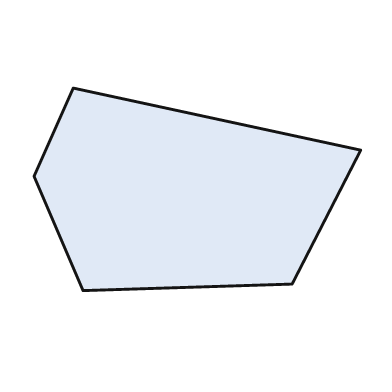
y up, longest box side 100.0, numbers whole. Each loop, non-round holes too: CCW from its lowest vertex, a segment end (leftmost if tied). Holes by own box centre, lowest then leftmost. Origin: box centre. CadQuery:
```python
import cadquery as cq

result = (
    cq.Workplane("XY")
    .moveTo(-35.0, -31.0)
    .lineTo(29.0, -29.0)
    .lineTo(50.0, 12.0)
    .lineTo(-38.0, 31.0)
    .lineTo(-50.0, 4.0)
    .close()
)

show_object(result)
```